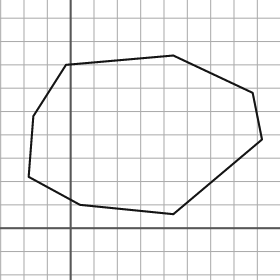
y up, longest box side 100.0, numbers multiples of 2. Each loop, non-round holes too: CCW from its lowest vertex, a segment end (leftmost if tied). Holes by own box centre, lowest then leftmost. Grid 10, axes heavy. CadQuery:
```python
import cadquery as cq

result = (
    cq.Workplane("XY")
    .moveTo(44.0, 6.0)
    .lineTo(82.0, 38.0)
    .lineTo(78.0, 58.0)
    .lineTo(44.0, 74.0)
    .lineTo(-2.0, 70.0)
    .lineTo(-16.0, 48.0)
    .lineTo(-18.0, 22.0)
    .lineTo(4.0, 10.0)
    .close()
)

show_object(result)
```